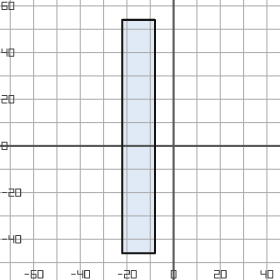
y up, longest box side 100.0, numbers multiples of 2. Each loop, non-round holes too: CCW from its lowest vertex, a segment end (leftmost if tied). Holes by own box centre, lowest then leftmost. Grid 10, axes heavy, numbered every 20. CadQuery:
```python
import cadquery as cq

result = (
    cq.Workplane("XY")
    .moveTo(-22.0, -46.0)
    .lineTo(-8.0, -46.0)
    .lineTo(-8.0, 54.0)
    .lineTo(-22.0, 54.0)
    .close()
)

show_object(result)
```